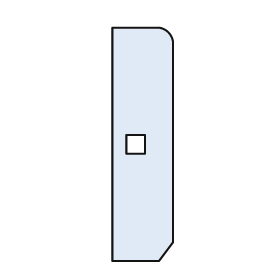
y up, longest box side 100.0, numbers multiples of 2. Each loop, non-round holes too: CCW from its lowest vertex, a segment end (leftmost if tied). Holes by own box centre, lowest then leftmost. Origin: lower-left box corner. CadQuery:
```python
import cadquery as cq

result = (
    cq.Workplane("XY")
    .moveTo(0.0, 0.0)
    .lineTo(20.0, 0.0)
    .lineTo(26.0, 8.0)
    .lineTo(26.0, 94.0)
    .threePointArc((24.0, 98.0), (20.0, 100.0))
    .lineTo(0.0, 100.0)
    .close()
    .moveTo(6.0, 46.0)
    .lineTo(14.0, 46.0)
    .lineTo(14.0, 54.0)
    .lineTo(6.0, 54.0)
    .close()
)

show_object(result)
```